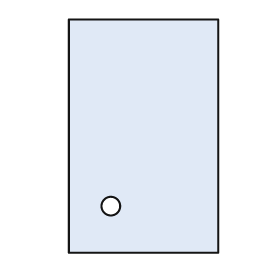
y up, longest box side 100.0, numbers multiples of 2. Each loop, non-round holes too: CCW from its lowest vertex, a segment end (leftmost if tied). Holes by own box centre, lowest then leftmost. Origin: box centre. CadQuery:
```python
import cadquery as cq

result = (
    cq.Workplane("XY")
    .moveTo(-32.0, -50.0)
    .lineTo(32.0, -50.0)
    .lineTo(32.0, 50.0)
    .lineTo(-32.0, 50.0)
    .close()
    .moveTo(-14.0, -30.0)
    .circle(4.0)
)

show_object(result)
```